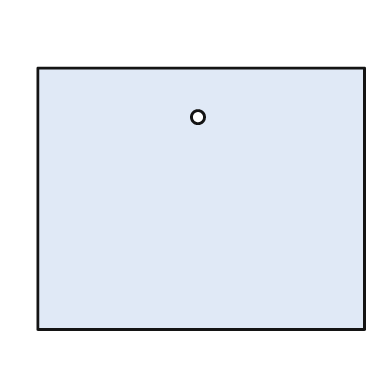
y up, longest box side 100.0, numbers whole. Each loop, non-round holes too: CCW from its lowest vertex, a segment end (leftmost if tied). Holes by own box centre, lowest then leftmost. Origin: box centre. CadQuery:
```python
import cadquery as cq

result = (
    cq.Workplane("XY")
    .moveTo(-50.0, -40.0)
    .lineTo(50.0, -40.0)
    .lineTo(50.0, 40.0)
    .lineTo(-50.0, 40.0)
    .close()
    .moveTo(-1.0, 25.0)
    .circle(2.0)
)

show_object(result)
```